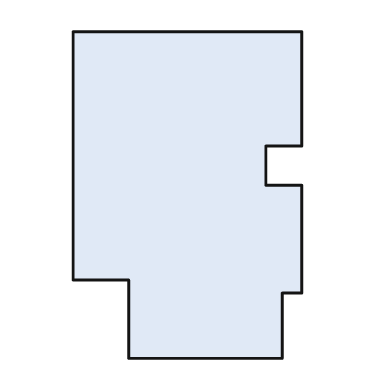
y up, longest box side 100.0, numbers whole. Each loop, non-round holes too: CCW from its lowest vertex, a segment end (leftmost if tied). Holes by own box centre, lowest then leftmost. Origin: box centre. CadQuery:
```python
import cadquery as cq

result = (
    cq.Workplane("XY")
    .moveTo(-18.0, -50.0)
    .lineTo(29.0, -50.0)
    .lineTo(29.0, -30.0)
    .lineTo(35.0, -30.0)
    .lineTo(35.0, 3.0)
    .lineTo(24.0, 3.0)
    .lineTo(24.0, 15.0)
    .lineTo(35.0, 15.0)
    .lineTo(35.0, 50.0)
    .lineTo(-35.0, 50.0)
    .lineTo(-35.0, -26.0)
    .lineTo(-18.0, -26.0)
    .close()
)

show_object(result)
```